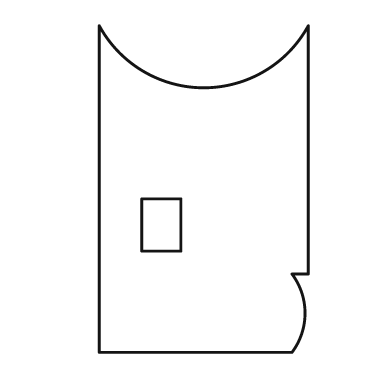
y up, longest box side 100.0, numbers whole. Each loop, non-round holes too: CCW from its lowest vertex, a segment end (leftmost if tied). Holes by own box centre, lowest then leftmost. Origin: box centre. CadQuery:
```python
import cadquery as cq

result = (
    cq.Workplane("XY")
    .moveTo(-32.0, -50.0)
    .lineTo(27.0, -50.0)
    .threePointArc((31.0, -38.0), (27.0, -26.0))
    .lineTo(32.0, -26.0)
    .lineTo(32.0, 50.0)
    .threePointArc((0.0, 31.0), (-32.0, 50.0))
    .close()
    .moveTo(-19.0, -19.0)
    .lineTo(-7.0, -19.0)
    .lineTo(-7.0, -3.0)
    .lineTo(-19.0, -3.0)
    .close()
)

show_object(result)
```